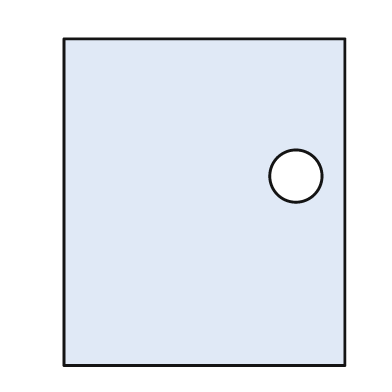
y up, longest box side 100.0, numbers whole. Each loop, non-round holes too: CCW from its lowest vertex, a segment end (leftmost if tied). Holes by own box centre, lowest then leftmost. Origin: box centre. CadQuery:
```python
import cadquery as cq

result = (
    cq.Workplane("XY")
    .moveTo(-43.0, -50.0)
    .lineTo(43.0, -50.0)
    .lineTo(43.0, 50.0)
    .lineTo(-43.0, 50.0)
    .close()
    .moveTo(28.0, 8.0)
    .circle(8.0)
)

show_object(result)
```